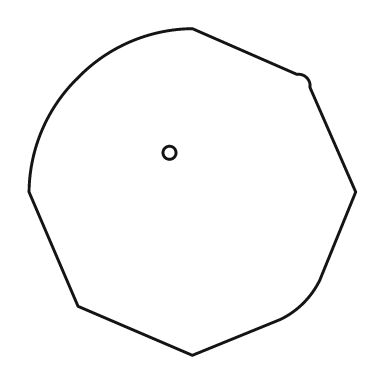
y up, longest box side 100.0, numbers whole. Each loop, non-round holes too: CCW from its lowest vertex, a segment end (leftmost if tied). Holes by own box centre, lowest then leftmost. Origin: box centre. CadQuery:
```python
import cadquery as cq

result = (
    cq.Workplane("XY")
    .moveTo(0.0, -50.0)
    .lineTo(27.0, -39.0)
    .threePointArc((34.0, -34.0), (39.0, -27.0))
    .lineTo(50.0, 0.0)
    .lineTo(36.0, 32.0)
    .threePointArc((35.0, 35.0), (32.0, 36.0))
    .lineTo(0.0, 50.0)
    .threePointArc((-19.0, 46.0), (-35.0, 35.0))
    .threePointArc((-46.0, 19.0), (-50.0, 0.0))
    .lineTo(-35.0, -35.0)
    .close()
    .moveTo(-7.0, 12.0)
    .circle(2.0)
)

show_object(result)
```